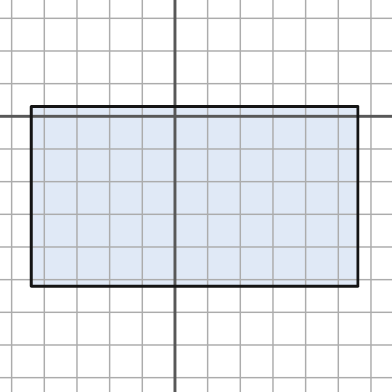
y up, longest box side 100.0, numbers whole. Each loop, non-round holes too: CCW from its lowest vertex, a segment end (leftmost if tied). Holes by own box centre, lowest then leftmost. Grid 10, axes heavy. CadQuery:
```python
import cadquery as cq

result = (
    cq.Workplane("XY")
    .moveTo(-44.0, -52.0)
    .lineTo(56.0, -52.0)
    .lineTo(56.0, 3.0)
    .lineTo(-44.0, 3.0)
    .close()
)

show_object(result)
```